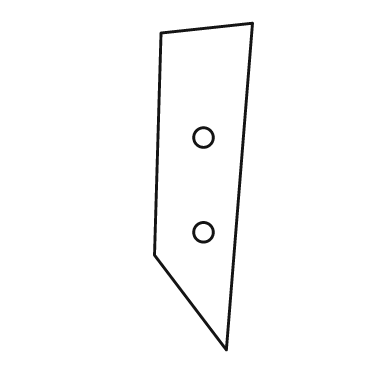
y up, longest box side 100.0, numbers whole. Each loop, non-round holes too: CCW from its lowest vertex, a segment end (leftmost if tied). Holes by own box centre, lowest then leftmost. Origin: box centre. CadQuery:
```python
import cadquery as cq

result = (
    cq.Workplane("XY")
    .moveTo(7.0, -50.0)
    .lineTo(15.0, 50.0)
    .lineTo(-13.0, 47.0)
    .lineTo(-15.0, -21.0)
    .close()
    .moveTo(0.0, -14.0)
    .circle(3.0)
    .moveTo(0.0, 15.0)
    .circle(3.0)
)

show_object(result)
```